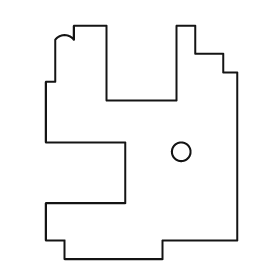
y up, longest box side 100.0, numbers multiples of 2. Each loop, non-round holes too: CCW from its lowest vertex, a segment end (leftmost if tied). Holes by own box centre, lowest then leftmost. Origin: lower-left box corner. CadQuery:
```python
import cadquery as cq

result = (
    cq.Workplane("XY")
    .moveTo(8.0, 0.0)
    .lineTo(50.0, 0.0)
    .lineTo(50.0, 8.0)
    .lineTo(82.0, 8.0)
    .lineTo(82.0, 80.0)
    .lineTo(76.0, 80.0)
    .lineTo(76.0, 88.0)
    .lineTo(64.0, 88.0)
    .lineTo(64.0, 100.0)
    .lineTo(56.0, 100.0)
    .lineTo(56.0, 68.0)
    .lineTo(26.0, 68.0)
    .lineTo(26.0, 100.0)
    .lineTo(12.0, 100.0)
    .lineTo(12.0, 94.0)
    .threePointArc((8.0, 96.0), (4.0, 94.0))
    .lineTo(4.0, 76.0)
    .lineTo(0.0, 76.0)
    .lineTo(0.0, 50.0)
    .lineTo(34.0, 50.0)
    .lineTo(34.0, 24.0)
    .lineTo(0.0, 24.0)
    .lineTo(0.0, 8.0)
    .lineTo(8.0, 8.0)
    .close()
    .moveTo(58.0, 46.0)
    .circle(4.0)
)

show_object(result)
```